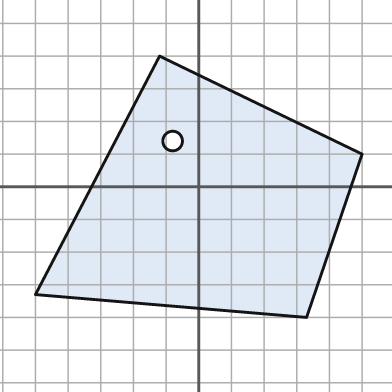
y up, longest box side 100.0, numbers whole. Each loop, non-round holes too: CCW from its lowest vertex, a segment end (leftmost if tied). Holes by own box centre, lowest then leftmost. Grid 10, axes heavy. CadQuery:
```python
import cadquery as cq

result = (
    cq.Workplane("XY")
    .moveTo(33.0, -40.0)
    .lineTo(50.0, 10.0)
    .lineTo(-12.0, 40.0)
    .lineTo(-50.0, -33.0)
    .close()
    .moveTo(-8.0, 14.0)
    .circle(3.0)
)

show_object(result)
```